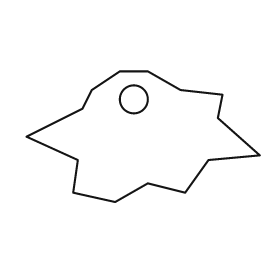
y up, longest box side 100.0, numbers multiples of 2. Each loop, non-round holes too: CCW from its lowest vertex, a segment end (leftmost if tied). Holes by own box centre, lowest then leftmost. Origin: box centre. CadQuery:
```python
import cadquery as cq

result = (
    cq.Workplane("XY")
    .moveTo(-12.0, -28.0)
    .lineTo(2.0, -20.0)
    .lineTo(18.0, -24.0)
    .lineTo(28.0, -10.0)
    .lineTo(50.0, -8.0)
    .lineTo(32.0, 8.0)
    .lineTo(34.0, 18.0)
    .lineTo(16.0, 20.0)
    .lineTo(2.0, 28.0)
    .lineTo(-10.0, 28.0)
    .lineTo(-22.0, 20.0)
    .lineTo(-26.0, 12.0)
    .lineTo(-50.0, 0.0)
    .lineTo(-28.0, -10.0)
    .lineTo(-30.0, -24.0)
    .close()
    .moveTo(-4.0, 16.0)
    .circle(6.0)
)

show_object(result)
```